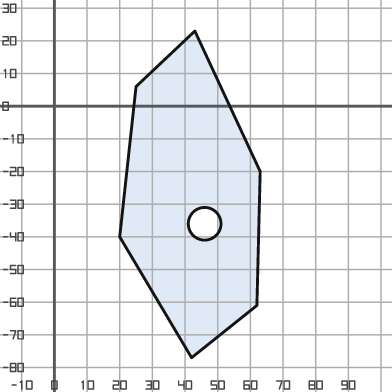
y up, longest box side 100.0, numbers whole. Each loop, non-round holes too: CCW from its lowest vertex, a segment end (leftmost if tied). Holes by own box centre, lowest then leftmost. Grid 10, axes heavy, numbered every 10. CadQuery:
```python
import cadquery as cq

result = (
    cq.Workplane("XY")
    .moveTo(42.0, -77.0)
    .lineTo(62.0, -61.0)
    .lineTo(63.0, -20.0)
    .lineTo(43.0, 23.0)
    .lineTo(25.0, 6.0)
    .lineTo(20.0, -40.0)
    .close()
    .moveTo(46.0, -36.0)
    .circle(5.0)
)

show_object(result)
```